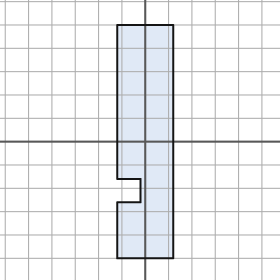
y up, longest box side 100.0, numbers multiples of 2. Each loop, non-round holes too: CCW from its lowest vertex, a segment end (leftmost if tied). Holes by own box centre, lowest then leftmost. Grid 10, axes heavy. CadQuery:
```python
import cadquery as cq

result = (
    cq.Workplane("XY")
    .moveTo(-12.0, -50.0)
    .lineTo(12.0, -50.0)
    .lineTo(12.0, 50.0)
    .lineTo(-12.0, 50.0)
    .lineTo(-12.0, -16.0)
    .lineTo(-2.0, -16.0)
    .lineTo(-2.0, -26.0)
    .lineTo(-12.0, -26.0)
    .close()
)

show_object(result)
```